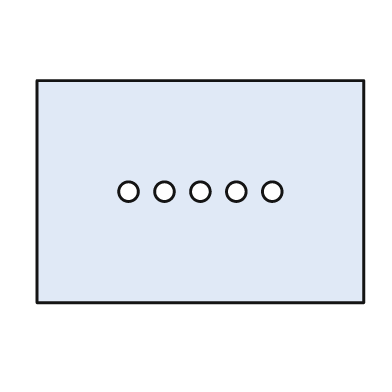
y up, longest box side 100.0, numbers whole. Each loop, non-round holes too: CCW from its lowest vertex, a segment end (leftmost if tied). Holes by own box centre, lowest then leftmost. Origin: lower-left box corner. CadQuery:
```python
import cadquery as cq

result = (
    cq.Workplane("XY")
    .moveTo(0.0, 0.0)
    .lineTo(100.0, 0.0)
    .lineTo(100.0, 68.0)
    .lineTo(0.0, 68.0)
    .close()
    .moveTo(28.0, 34.0)
    .circle(3.0)
    .moveTo(39.0, 34.0)
    .circle(3.0)
    .moveTo(50.0, 34.0)
    .circle(3.0)
    .moveTo(61.0, 34.0)
    .circle(3.0)
    .moveTo(72.0, 34.0)
    .circle(3.0)
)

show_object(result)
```